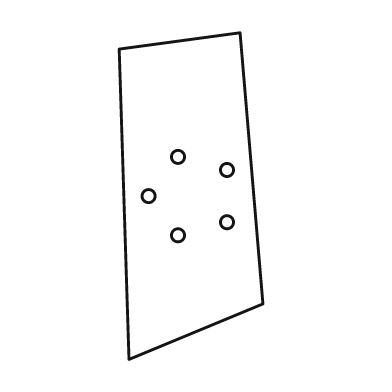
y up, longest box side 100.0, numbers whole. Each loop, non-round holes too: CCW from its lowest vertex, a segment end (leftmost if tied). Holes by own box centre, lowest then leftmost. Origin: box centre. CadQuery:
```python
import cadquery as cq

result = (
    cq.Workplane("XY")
    .moveTo(-19.0, -50.0)
    .lineTo(22.0, -33.0)
    .lineTo(15.0, 50.0)
    .lineTo(-22.0, 45.0)
    .close()
    .moveTo(-4.0, -12.0)
    .circle(2.0)
    .moveTo(11.0, -8.0)
    .circle(2.0)
    .moveTo(-13.0, 0.0)
    .circle(2.0)
    .moveTo(11.0, 8.0)
    .circle(2.0)
    .moveTo(-4.0, 12.0)
    .circle(2.0)
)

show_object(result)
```